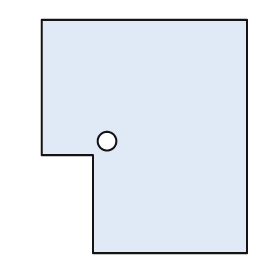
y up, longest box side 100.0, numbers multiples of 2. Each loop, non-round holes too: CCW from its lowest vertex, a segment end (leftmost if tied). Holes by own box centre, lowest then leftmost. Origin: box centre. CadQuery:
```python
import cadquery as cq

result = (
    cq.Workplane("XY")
    .moveTo(-22.0, -50.0)
    .lineTo(44.0, -50.0)
    .lineTo(44.0, 50.0)
    .lineTo(-44.0, 50.0)
    .lineTo(-44.0, -8.0)
    .lineTo(-22.0, -8.0)
    .close()
    .moveTo(-16.0, -2.0)
    .circle(4.0)
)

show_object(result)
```